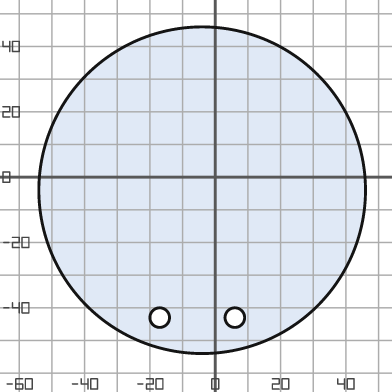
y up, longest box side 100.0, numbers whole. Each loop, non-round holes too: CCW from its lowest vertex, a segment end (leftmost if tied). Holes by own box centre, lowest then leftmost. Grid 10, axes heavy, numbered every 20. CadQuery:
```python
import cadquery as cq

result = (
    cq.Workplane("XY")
    .moveTo(-4.0, -4.0)
    .circle(50.0)
    .moveTo(-17.0, -43.0)
    .circle(3.0)
    .moveTo(6.0, -43.0)
    .circle(3.0)
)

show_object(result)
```